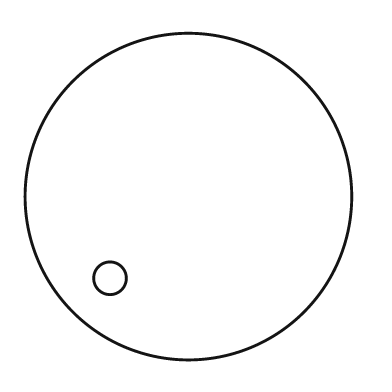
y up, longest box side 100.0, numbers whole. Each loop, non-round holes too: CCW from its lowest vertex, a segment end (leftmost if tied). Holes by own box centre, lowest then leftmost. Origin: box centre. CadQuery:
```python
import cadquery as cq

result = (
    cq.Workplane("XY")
    .moveTo(0.0, 0.0)
    .circle(50.0)
    .moveTo(-24.0, -25.0)
    .circle(5.0)
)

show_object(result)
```